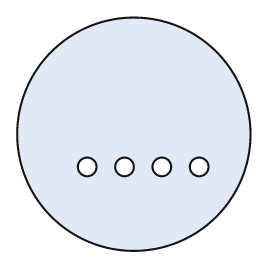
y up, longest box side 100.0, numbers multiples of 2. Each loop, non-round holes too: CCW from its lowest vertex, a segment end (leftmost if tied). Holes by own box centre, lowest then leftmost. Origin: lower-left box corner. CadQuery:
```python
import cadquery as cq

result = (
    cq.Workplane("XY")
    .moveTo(50.0, 50.0)
    .circle(50.0)
    .moveTo(30.0, 36.0)
    .circle(4.0)
    .moveTo(46.0, 36.0)
    .circle(4.0)
    .moveTo(62.0, 36.0)
    .circle(4.0)
    .moveTo(78.0, 36.0)
    .circle(4.0)
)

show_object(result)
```